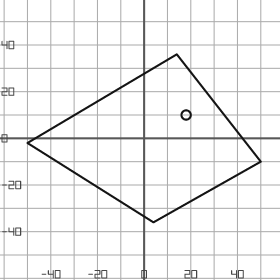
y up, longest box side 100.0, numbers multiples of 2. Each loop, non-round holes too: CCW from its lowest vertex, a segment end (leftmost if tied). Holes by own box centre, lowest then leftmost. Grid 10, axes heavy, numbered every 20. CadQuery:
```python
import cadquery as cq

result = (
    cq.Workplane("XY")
    .moveTo(4.0, -36.0)
    .lineTo(50.0, -10.0)
    .lineTo(14.0, 36.0)
    .lineTo(-50.0, -2.0)
    .close()
    .moveTo(18.0, 10.0)
    .circle(2.0)
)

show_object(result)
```